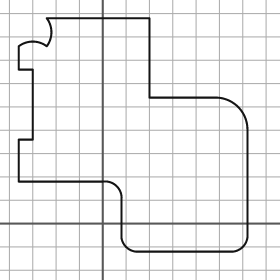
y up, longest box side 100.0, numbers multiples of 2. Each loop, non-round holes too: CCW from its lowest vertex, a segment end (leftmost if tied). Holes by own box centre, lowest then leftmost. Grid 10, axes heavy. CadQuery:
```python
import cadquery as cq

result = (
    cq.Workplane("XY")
    .moveTo(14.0, -12.0)
    .lineTo(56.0, -12.0)
    .threePointArc((60.0, -10.0), (62.0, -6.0))
    .lineTo(62.0, 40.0)
    .threePointArc((58.0, 50.0), (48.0, 54.0))
    .lineTo(20.0, 54.0)
    .lineTo(20.0, 88.0)
    .lineTo(-24.0, 88.0)
    .threePointArc((-22.0, 82.0), (-24.0, 76.0))
    .threePointArc((-30.0, 78.0), (-36.0, 76.0))
    .lineTo(-36.0, 66.0)
    .lineTo(-30.0, 66.0)
    .lineTo(-30.0, 36.0)
    .lineTo(-36.0, 36.0)
    .lineTo(-36.0, 18.0)
    .lineTo(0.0, 18.0)
    .threePointArc((6.0, 16.0), (8.0, 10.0))
    .lineTo(8.0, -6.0)
    .threePointArc((10.0, -10.0), (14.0, -12.0))
    .close()
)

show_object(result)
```